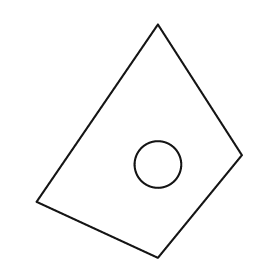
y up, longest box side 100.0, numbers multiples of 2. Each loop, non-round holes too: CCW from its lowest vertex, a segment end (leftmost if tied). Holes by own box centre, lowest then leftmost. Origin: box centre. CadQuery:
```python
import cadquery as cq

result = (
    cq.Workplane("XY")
    .moveTo(8.0, -50.0)
    .lineTo(44.0, -6.0)
    .lineTo(8.0, 50.0)
    .lineTo(-44.0, -26.0)
    .close()
    .moveTo(8.0, -10.0)
    .circle(10.0)
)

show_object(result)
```